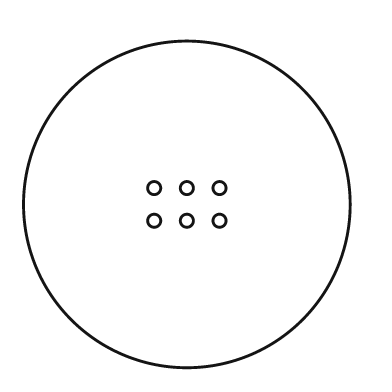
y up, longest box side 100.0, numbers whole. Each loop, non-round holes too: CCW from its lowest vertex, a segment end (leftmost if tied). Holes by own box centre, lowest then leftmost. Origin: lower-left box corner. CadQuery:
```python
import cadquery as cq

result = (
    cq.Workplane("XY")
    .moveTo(50.0, 50.0)
    .circle(50.0)
    .moveTo(40.0, 45.0)
    .circle(2.0)
    .moveTo(50.0, 45.0)
    .circle(2.0)
    .moveTo(60.0, 45.0)
    .circle(2.0)
    .moveTo(40.0, 55.0)
    .circle(2.0)
    .moveTo(50.0, 55.0)
    .circle(2.0)
    .moveTo(60.0, 55.0)
    .circle(2.0)
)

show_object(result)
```